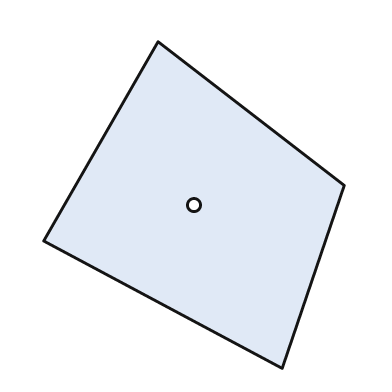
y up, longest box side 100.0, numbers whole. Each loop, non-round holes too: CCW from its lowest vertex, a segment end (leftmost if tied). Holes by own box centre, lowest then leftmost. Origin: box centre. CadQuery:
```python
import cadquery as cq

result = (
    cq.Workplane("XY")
    .moveTo(27.0, -50.0)
    .lineTo(46.0, 6.0)
    .lineTo(-11.0, 50.0)
    .lineTo(-46.0, -11.0)
    .close()
    .moveTo(0.0, 0.0)
    .circle(2.0)
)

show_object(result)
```